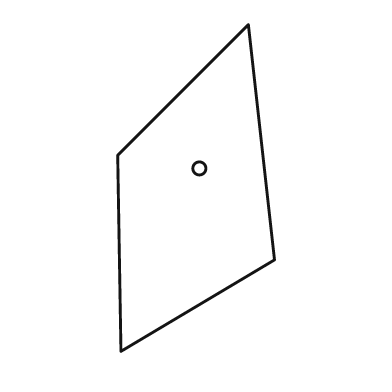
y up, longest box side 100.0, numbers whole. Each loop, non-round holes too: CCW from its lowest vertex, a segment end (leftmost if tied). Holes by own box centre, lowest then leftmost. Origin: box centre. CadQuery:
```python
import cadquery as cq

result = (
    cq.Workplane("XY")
    .moveTo(-23.0, -50.0)
    .lineTo(24.0, -22.0)
    .lineTo(16.0, 50.0)
    .lineTo(-24.0, 10.0)
    .close()
    .moveTo(1.0, 6.0)
    .circle(2.0)
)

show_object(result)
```